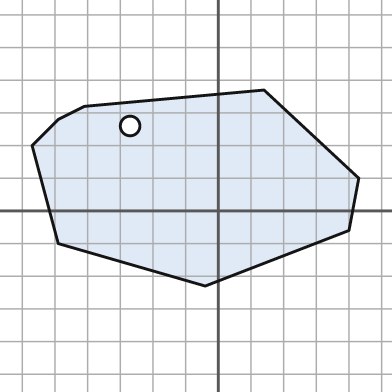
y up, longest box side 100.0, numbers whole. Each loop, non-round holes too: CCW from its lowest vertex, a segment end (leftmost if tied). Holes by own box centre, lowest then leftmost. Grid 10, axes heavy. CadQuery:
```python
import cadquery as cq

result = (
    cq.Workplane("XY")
    .moveTo(-4.0, -23.0)
    .lineTo(40.0, -6.0)
    .lineTo(43.0, 10.0)
    .lineTo(14.0, 37.0)
    .lineTo(-41.0, 32.0)
    .lineTo(-49.0, 28.0)
    .lineTo(-57.0, 20.0)
    .lineTo(-49.0, -10.0)
    .close()
    .moveTo(-27.0, 26.0)
    .circle(3.0)
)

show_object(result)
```